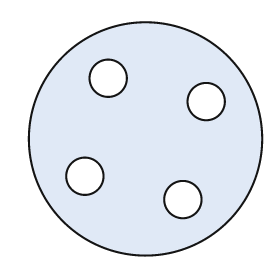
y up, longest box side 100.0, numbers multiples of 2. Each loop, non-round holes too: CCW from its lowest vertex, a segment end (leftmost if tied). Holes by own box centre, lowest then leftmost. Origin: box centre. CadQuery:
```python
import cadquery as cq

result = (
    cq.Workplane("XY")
    .moveTo(0.0, 0.0)
    .circle(50.0)
    .moveTo(16.0, -26.0)
    .circle(8.0)
    .moveTo(-26.0, -16.0)
    .circle(8.0)
    .moveTo(26.0, 16.0)
    .circle(8.0)
    .moveTo(-16.0, 26.0)
    .circle(8.0)
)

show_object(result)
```